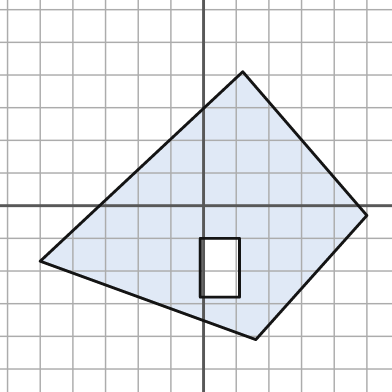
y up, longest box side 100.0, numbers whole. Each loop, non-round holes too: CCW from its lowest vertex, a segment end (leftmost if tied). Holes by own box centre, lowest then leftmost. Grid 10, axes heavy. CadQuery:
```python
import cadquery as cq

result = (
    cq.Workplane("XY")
    .moveTo(16.0, -41.0)
    .lineTo(50.0, -3.0)
    .lineTo(12.0, 41.0)
    .lineTo(-50.0, -17.0)
    .close()
    .moveTo(-1.0, -28.0)
    .lineTo(11.0, -28.0)
    .lineTo(11.0, -10.0)
    .lineTo(-1.0, -10.0)
    .close()
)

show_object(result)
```